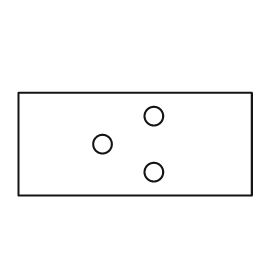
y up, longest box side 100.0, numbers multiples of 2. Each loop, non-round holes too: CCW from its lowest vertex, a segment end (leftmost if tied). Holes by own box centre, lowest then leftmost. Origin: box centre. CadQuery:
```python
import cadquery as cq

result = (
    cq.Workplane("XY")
    .moveTo(-50.0, -22.0)
    .lineTo(50.0, -22.0)
    .lineTo(50.0, 22.0)
    .lineTo(-50.0, 22.0)
    .close()
    .moveTo(8.0, -12.0)
    .circle(4.0)
    .moveTo(-14.0, 0.0)
    .circle(4.0)
    .moveTo(8.0, 12.0)
    .circle(4.0)
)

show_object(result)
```